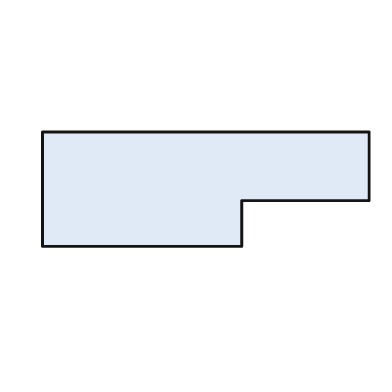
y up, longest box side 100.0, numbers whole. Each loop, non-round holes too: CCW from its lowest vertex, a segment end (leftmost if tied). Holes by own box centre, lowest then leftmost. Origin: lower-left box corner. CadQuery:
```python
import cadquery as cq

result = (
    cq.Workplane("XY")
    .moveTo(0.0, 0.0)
    .lineTo(61.0, 0.0)
    .lineTo(61.0, 14.0)
    .lineTo(100.0, 14.0)
    .lineTo(100.0, 35.0)
    .lineTo(0.0, 35.0)
    .close()
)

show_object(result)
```